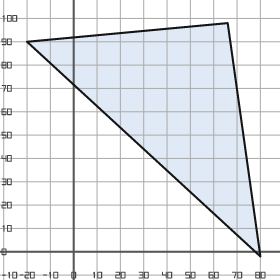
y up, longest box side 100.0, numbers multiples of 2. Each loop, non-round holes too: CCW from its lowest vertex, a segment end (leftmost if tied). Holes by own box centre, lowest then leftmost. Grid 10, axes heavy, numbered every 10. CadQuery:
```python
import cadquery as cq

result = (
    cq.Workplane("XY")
    .moveTo(80.0, -2.0)
    .lineTo(66.0, 98.0)
    .lineTo(-20.0, 90.0)
    .close()
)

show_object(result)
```